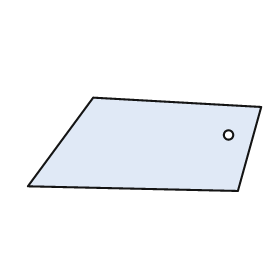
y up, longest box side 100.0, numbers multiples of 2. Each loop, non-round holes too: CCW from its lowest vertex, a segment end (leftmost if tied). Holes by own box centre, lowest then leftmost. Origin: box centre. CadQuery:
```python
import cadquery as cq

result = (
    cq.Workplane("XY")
    .moveTo(40.0, -20.0)
    .lineTo(50.0, 16.0)
    .lineTo(-22.0, 20.0)
    .lineTo(-50.0, -18.0)
    .close()
    .moveTo(36.0, 4.0)
    .circle(2.0)
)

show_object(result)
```